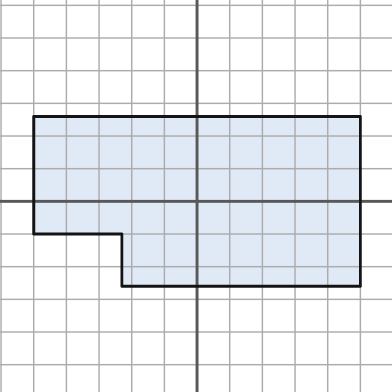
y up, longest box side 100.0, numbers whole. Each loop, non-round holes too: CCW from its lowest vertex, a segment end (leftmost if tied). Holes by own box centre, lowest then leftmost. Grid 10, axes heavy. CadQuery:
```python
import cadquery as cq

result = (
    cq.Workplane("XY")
    .moveTo(-23.0, -26.0)
    .lineTo(50.0, -26.0)
    .lineTo(50.0, 26.0)
    .lineTo(-50.0, 26.0)
    .lineTo(-50.0, -10.0)
    .lineTo(-23.0, -10.0)
    .close()
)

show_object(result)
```